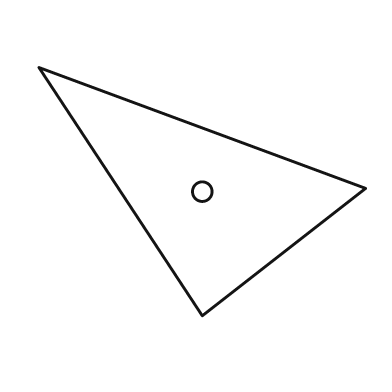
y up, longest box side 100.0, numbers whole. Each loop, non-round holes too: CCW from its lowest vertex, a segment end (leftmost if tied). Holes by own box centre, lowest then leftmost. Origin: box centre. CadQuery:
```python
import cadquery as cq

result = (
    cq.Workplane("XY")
    .moveTo(0.0, -38.0)
    .lineTo(50.0, 1.0)
    .lineTo(-50.0, 38.0)
    .close()
    .moveTo(0.0, 0.0)
    .circle(3.0)
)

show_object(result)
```